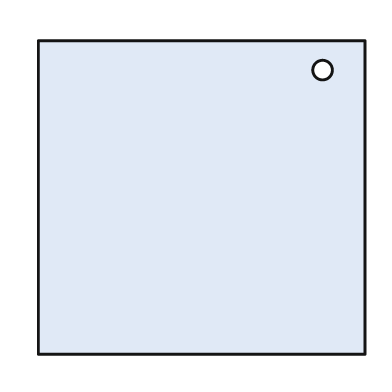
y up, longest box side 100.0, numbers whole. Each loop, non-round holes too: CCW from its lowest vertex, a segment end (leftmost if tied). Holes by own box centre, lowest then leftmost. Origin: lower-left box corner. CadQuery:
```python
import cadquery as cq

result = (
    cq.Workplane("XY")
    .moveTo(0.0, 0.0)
    .lineTo(100.0, 0.0)
    .lineTo(100.0, 96.0)
    .lineTo(0.0, 96.0)
    .close()
    .moveTo(87.0, 87.0)
    .circle(3.0)
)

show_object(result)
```